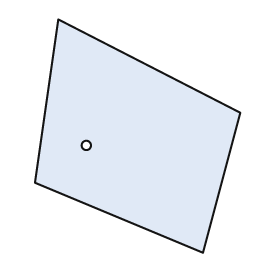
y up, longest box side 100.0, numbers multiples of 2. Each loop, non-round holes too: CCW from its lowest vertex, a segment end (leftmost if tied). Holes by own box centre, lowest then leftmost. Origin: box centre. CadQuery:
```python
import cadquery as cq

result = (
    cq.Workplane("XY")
    .moveTo(28.0, -50.0)
    .lineTo(44.0, 10.0)
    .lineTo(-34.0, 50.0)
    .lineTo(-44.0, -20.0)
    .close()
    .moveTo(-22.0, -4.0)
    .circle(2.0)
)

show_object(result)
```